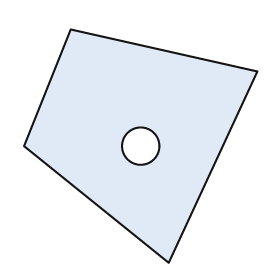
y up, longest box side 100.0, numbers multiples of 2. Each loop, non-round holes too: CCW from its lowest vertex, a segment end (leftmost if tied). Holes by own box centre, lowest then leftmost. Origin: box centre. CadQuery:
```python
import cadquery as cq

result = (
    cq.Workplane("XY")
    .moveTo(12.0, -50.0)
    .lineTo(50.0, 32.0)
    .lineTo(-30.0, 50.0)
    .lineTo(-50.0, 0.0)
    .close()
    .moveTo(0.0, 0.0)
    .circle(8.0)
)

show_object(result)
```